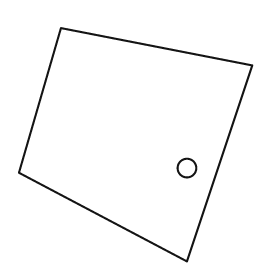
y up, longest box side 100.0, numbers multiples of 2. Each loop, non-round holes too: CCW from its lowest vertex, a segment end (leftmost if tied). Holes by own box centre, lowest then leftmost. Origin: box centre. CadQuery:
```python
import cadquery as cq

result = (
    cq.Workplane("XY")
    .moveTo(22.0, -50.0)
    .lineTo(50.0, 34.0)
    .lineTo(-32.0, 50.0)
    .lineTo(-50.0, -12.0)
    .close()
    .moveTo(22.0, -10.0)
    .circle(4.0)
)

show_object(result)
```